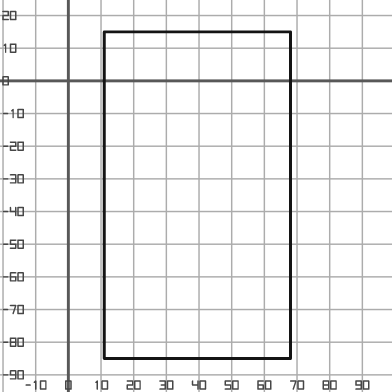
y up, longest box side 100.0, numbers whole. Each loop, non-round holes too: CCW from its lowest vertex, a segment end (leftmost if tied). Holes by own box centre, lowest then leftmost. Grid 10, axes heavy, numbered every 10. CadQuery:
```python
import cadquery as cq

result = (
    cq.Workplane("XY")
    .moveTo(11.0, -85.0)
    .lineTo(68.0, -85.0)
    .lineTo(68.0, 15.0)
    .lineTo(11.0, 15.0)
    .close()
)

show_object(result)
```